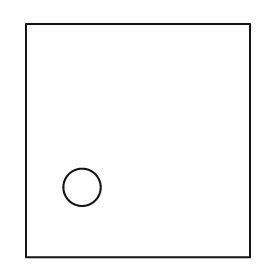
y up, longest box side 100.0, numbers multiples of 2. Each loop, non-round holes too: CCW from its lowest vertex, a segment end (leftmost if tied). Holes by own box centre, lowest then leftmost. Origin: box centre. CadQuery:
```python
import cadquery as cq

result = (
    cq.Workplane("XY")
    .moveTo(-48.0, -50.0)
    .lineTo(48.0, -50.0)
    .lineTo(48.0, 50.0)
    .lineTo(-48.0, 50.0)
    .close()
    .moveTo(-24.0, -20.0)
    .circle(8.0)
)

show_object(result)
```